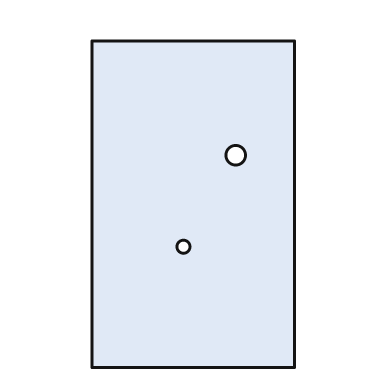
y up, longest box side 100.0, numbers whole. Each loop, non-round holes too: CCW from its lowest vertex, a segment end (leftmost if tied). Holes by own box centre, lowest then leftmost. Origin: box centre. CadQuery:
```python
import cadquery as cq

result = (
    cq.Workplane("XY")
    .moveTo(-31.0, -50.0)
    .lineTo(31.0, -50.0)
    .lineTo(31.0, 50.0)
    .lineTo(-31.0, 50.0)
    .close()
    .moveTo(-3.0, -13.0)
    .circle(2.0)
    .moveTo(13.0, 15.0)
    .circle(3.0)
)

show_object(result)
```